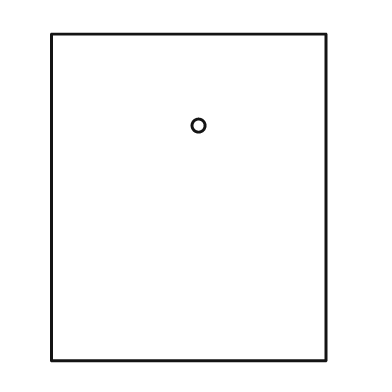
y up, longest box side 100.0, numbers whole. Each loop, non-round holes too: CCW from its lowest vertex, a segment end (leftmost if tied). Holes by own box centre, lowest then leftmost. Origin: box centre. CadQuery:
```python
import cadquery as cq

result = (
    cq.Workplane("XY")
    .moveTo(-42.0, -50.0)
    .lineTo(42.0, -50.0)
    .lineTo(42.0, 50.0)
    .lineTo(-42.0, 50.0)
    .close()
    .moveTo(3.0, 22.0)
    .circle(2.0)
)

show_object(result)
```